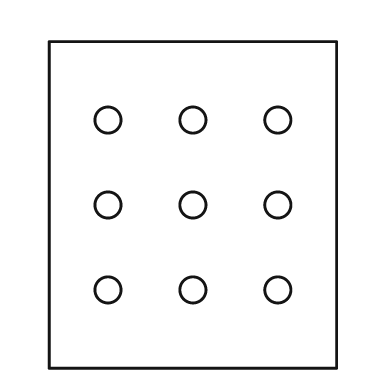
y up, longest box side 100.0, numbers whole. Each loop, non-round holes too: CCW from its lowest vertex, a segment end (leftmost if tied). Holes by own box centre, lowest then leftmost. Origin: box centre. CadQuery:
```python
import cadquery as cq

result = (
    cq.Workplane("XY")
    .moveTo(-44.0, -50.0)
    .lineTo(44.0, -50.0)
    .lineTo(44.0, 50.0)
    .lineTo(-44.0, 50.0)
    .close()
    .moveTo(-26.0, -26.0)
    .circle(4.0)
    .moveTo(0.0, -26.0)
    .circle(4.0)
    .moveTo(26.0, -26.0)
    .circle(4.0)
    .moveTo(-26.0, 0.0)
    .circle(4.0)
    .moveTo(0.0, 0.0)
    .circle(4.0)
    .moveTo(26.0, 0.0)
    .circle(4.0)
    .moveTo(-26.0, 26.0)
    .circle(4.0)
    .moveTo(0.0, 26.0)
    .circle(4.0)
    .moveTo(26.0, 26.0)
    .circle(4.0)
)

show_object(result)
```